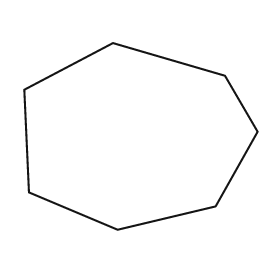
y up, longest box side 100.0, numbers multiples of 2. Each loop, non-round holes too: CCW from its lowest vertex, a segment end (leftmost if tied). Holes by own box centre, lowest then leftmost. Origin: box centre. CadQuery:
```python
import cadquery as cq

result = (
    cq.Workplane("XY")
    .moveTo(-10.0, -40.0)
    .lineTo(32.0, -30.0)
    .lineTo(50.0, 2.0)
    .lineTo(36.0, 26.0)
    .lineTo(-12.0, 40.0)
    .lineTo(-50.0, 20.0)
    .lineTo(-48.0, -24.0)
    .close()
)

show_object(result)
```